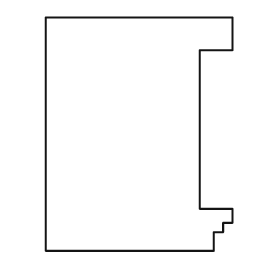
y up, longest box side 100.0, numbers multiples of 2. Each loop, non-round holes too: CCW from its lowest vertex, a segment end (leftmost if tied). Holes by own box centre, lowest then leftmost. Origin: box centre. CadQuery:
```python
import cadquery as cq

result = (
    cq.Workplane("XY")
    .moveTo(-40.0, -50.0)
    .lineTo(32.0, -50.0)
    .lineTo(32.0, -42.0)
    .lineTo(36.0, -42.0)
    .lineTo(36.0, -38.0)
    .lineTo(40.0, -38.0)
    .lineTo(40.0, -32.0)
    .lineTo(26.0, -32.0)
    .lineTo(26.0, 36.0)
    .lineTo(40.0, 36.0)
    .lineTo(40.0, 50.0)
    .lineTo(-40.0, 50.0)
    .close()
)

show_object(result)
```